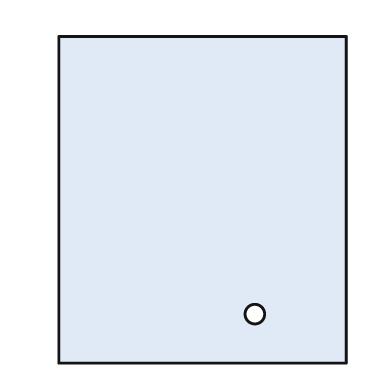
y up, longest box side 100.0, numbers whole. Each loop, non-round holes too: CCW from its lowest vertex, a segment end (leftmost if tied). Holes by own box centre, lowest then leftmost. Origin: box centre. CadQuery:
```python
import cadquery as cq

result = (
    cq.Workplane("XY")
    .moveTo(-44.0, -50.0)
    .lineTo(44.0, -50.0)
    .lineTo(44.0, 50.0)
    .lineTo(-44.0, 50.0)
    .close()
    .moveTo(16.0, -35.0)
    .circle(3.0)
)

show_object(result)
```